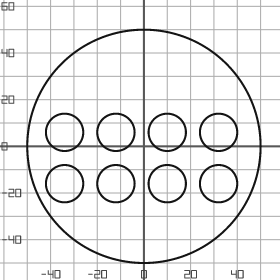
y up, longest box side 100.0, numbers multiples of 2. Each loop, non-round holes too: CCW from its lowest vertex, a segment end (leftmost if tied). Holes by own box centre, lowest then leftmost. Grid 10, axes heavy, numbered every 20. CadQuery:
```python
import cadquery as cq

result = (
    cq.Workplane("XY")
    .moveTo(0.0, 0.0)
    .circle(50.0)
    .moveTo(-34.0, -16.0)
    .circle(8.0)
    .moveTo(-12.0, -16.0)
    .circle(8.0)
    .moveTo(10.0, -16.0)
    .circle(8.0)
    .moveTo(32.0, -16.0)
    .circle(8.0)
    .moveTo(-34.0, 6.0)
    .circle(8.0)
    .moveTo(-12.0, 6.0)
    .circle(8.0)
    .moveTo(10.0, 6.0)
    .circle(8.0)
    .moveTo(32.0, 6.0)
    .circle(8.0)
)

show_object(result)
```